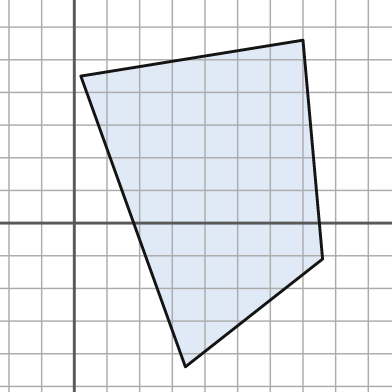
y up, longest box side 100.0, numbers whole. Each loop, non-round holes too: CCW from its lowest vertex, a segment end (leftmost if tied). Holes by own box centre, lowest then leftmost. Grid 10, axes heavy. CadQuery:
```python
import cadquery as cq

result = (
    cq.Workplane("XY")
    .moveTo(34.0, -44.0)
    .lineTo(76.0, -11.0)
    .lineTo(70.0, 56.0)
    .lineTo(2.0, 45.0)
    .close()
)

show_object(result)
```